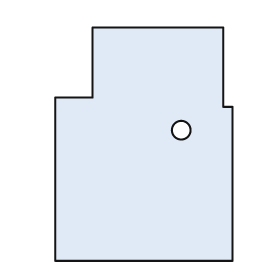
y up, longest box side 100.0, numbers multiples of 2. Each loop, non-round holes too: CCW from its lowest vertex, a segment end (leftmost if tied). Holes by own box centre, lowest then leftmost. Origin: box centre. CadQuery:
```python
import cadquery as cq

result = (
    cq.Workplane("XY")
    .moveTo(-38.0, -50.0)
    .lineTo(38.0, -50.0)
    .lineTo(38.0, 16.0)
    .lineTo(34.0, 16.0)
    .lineTo(34.0, 50.0)
    .lineTo(-22.0, 50.0)
    .lineTo(-22.0, 20.0)
    .lineTo(-38.0, 20.0)
    .close()
    .moveTo(16.0, 6.0)
    .circle(4.0)
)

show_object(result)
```